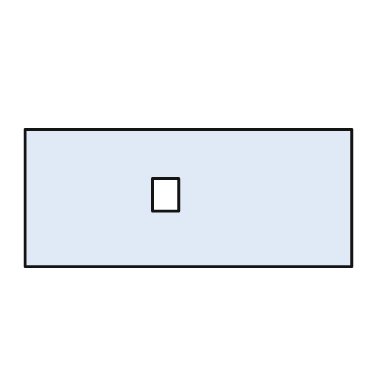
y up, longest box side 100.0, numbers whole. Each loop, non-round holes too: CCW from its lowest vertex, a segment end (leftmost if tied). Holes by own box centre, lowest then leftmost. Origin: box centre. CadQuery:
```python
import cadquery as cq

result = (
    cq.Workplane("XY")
    .moveTo(-50.0, -21.0)
    .lineTo(50.0, -21.0)
    .lineTo(50.0, 21.0)
    .lineTo(-50.0, 21.0)
    .close()
    .moveTo(-11.0, -4.0)
    .lineTo(-3.0, -4.0)
    .lineTo(-3.0, 6.0)
    .lineTo(-11.0, 6.0)
    .close()
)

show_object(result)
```